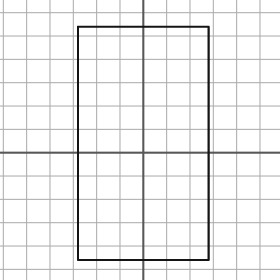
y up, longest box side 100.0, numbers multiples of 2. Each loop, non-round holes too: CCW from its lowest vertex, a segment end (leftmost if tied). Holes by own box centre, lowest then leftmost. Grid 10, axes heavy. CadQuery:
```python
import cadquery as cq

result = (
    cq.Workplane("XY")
    .moveTo(-28.0, -46.0)
    .lineTo(28.0, -46.0)
    .lineTo(28.0, 54.0)
    .lineTo(-28.0, 54.0)
    .close()
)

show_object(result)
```